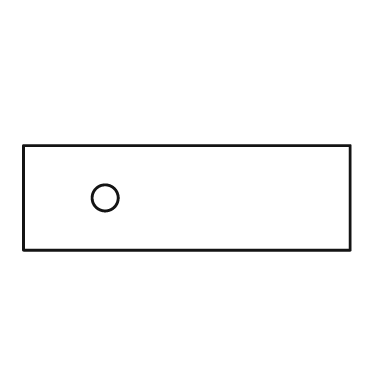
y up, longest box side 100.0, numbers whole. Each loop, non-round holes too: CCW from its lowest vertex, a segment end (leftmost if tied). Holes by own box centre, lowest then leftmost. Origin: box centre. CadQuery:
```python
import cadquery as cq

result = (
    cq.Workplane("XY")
    .moveTo(-50.0, -16.0)
    .lineTo(50.0, -16.0)
    .lineTo(50.0, 16.0)
    .lineTo(-50.0, 16.0)
    .close()
    .moveTo(-25.0, 0.0)
    .circle(4.0)
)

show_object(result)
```